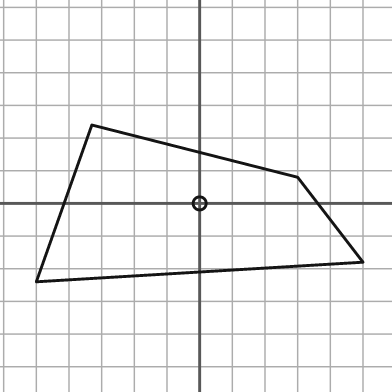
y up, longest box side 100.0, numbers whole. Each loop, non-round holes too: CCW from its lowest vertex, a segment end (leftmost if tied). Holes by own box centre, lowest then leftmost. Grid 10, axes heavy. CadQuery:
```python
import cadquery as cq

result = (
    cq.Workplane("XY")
    .moveTo(-50.0, -24.0)
    .lineTo(50.0, -18.0)
    .lineTo(30.0, 8.0)
    .lineTo(-33.0, 24.0)
    .close()
    .moveTo(0.0, 0.0)
    .circle(2.0)
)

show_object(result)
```